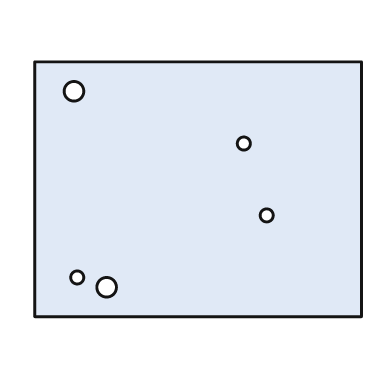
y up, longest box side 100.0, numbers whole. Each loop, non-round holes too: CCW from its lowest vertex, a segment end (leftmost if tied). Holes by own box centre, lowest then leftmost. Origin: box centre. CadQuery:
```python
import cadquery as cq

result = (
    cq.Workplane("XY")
    .moveTo(-50.0, -39.0)
    .lineTo(50.0, -39.0)
    .lineTo(50.0, 39.0)
    .lineTo(-50.0, 39.0)
    .close()
    .moveTo(-28.0, -30.0)
    .circle(3.0)
    .moveTo(-37.0, -27.0)
    .circle(2.0)
    .moveTo(21.0, -8.0)
    .circle(2.0)
    .moveTo(14.0, 14.0)
    .circle(2.0)
    .moveTo(-38.0, 30.0)
    .circle(3.0)
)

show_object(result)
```